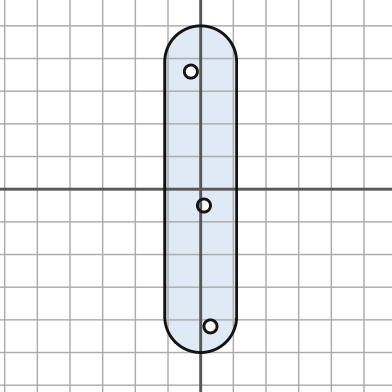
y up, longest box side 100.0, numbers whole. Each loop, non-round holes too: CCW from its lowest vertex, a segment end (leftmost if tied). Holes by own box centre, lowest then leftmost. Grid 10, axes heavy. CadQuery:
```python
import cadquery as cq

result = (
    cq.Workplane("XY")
    .moveTo(-11.0, -39.0)
    .threePointArc((0.0, -50.0), (11.0, -39.0))
    .lineTo(11.0, 39.0)
    .threePointArc((0.0, 50.0), (-11.0, 39.0))
    .close()
    .moveTo(3.0, -42.0)
    .circle(2.0)
    .moveTo(1.0, -5.0)
    .circle(2.0)
    .moveTo(-3.0, 36.0)
    .circle(2.0)
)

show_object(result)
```